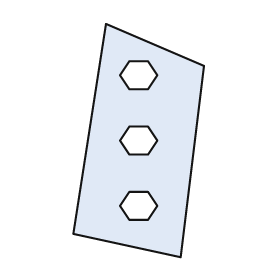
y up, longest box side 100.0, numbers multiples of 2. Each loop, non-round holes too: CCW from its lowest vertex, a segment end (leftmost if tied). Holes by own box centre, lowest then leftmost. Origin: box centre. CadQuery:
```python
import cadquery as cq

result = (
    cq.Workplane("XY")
    .moveTo(18.0, -50.0)
    .lineTo(28.0, 32.0)
    .lineTo(-14.0, 50.0)
    .lineTo(-28.0, -40.0)
    .close()
    .moveTo(-4.0, -34.0)
    .lineTo(4.0, -34.0)
    .lineTo(8.0, -28.0)
    .lineTo(4.0, -22.0)
    .lineTo(-4.0, -22.0)
    .lineTo(-8.0, -28.0)
    .close()
    .moveTo(-4.0, -6.0)
    .lineTo(4.0, -6.0)
    .lineTo(8.0, 0.0)
    .lineTo(4.0, 6.0)
    .lineTo(-4.0, 6.0)
    .lineTo(-8.0, 0.0)
    .close()
    .moveTo(-4.0, 22.0)
    .lineTo(4.0, 22.0)
    .lineTo(8.0, 28.0)
    .lineTo(4.0, 34.0)
    .lineTo(-4.0, 34.0)
    .lineTo(-8.0, 28.0)
    .close()
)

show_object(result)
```